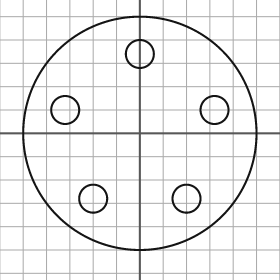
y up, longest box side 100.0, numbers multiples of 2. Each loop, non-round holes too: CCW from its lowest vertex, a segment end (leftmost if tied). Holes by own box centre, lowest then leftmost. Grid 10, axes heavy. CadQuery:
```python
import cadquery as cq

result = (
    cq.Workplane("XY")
    .moveTo(0.0, 0.0)
    .circle(50.0)
    .moveTo(-20.0, -28.0)
    .circle(6.0)
    .moveTo(20.0, -28.0)
    .circle(6.0)
    .moveTo(-32.0, 10.0)
    .circle(6.0)
    .moveTo(32.0, 10.0)
    .circle(6.0)
    .moveTo(0.0, 34.0)
    .circle(6.0)
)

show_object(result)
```